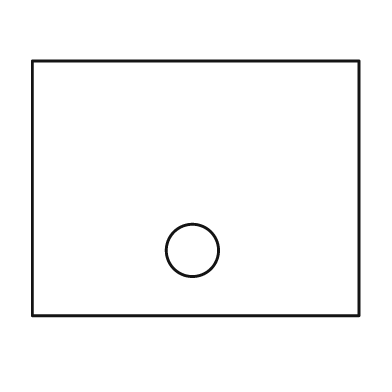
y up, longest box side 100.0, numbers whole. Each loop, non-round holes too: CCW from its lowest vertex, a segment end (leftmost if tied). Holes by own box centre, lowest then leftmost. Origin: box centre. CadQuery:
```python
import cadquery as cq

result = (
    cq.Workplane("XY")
    .moveTo(-50.0, -39.0)
    .lineTo(50.0, -39.0)
    .lineTo(50.0, 39.0)
    .lineTo(-50.0, 39.0)
    .close()
    .moveTo(-1.0, -19.0)
    .circle(8.0)
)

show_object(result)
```